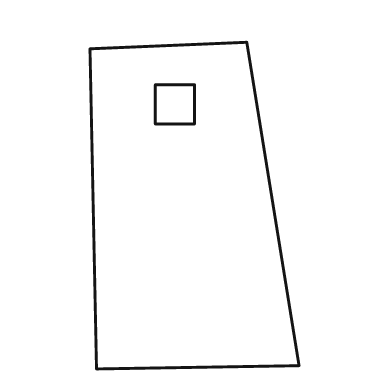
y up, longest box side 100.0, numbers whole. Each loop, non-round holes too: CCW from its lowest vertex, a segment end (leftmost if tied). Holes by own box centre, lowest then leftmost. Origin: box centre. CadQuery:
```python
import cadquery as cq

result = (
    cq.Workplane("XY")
    .moveTo(-30.0, -50.0)
    .lineTo(32.0, -49.0)
    .lineTo(16.0, 50.0)
    .lineTo(-32.0, 48.0)
    .close()
    .moveTo(-12.0, 25.0)
    .lineTo(0.0, 25.0)
    .lineTo(0.0, 37.0)
    .lineTo(-12.0, 37.0)
    .close()
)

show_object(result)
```